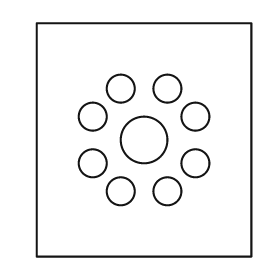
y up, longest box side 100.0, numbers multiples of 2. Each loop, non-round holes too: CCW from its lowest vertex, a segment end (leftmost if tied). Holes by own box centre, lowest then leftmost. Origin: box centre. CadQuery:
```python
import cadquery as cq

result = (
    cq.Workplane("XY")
    .moveTo(-46.0, -50.0)
    .lineTo(46.0, -50.0)
    .lineTo(46.0, 50.0)
    .lineTo(-46.0, 50.0)
    .close()
    .moveTo(-10.0, -22.0)
    .circle(6.0)
    .moveTo(10.0, -22.0)
    .circle(6.0)
    .moveTo(-22.0, -10.0)
    .circle(6.0)
    .moveTo(22.0, -10.0)
    .circle(6.0)
    .moveTo(0.0, 0.0)
    .circle(10.0)
    .moveTo(-22.0, 10.0)
    .circle(6.0)
    .moveTo(22.0, 10.0)
    .circle(6.0)
    .moveTo(-10.0, 22.0)
    .circle(6.0)
    .moveTo(10.0, 22.0)
    .circle(6.0)
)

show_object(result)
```